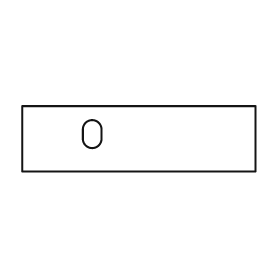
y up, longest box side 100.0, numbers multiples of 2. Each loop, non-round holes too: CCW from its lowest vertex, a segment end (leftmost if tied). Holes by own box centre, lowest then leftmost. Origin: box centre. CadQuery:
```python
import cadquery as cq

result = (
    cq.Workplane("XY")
    .moveTo(-50.0, -14.0)
    .lineTo(50.0, -14.0)
    .lineTo(50.0, 14.0)
    .lineTo(-50.0, 14.0)
    .close()
    .moveTo(-24.0, 0.0)
    .threePointArc((-20.0, -4.0), (-16.0, 0.0))
    .lineTo(-16.0, 4.0)
    .threePointArc((-20.0, 8.0), (-24.0, 4.0))
    .close()
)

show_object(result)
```